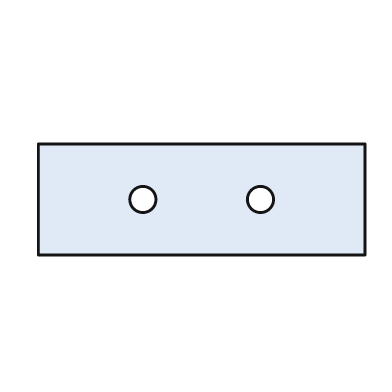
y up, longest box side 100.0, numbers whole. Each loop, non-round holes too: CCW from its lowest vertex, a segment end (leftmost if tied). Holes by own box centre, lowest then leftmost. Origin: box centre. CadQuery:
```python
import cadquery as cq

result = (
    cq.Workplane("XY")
    .moveTo(-50.0, -17.0)
    .lineTo(50.0, -17.0)
    .lineTo(50.0, 17.0)
    .lineTo(-50.0, 17.0)
    .close()
    .moveTo(-18.0, 0.0)
    .circle(4.0)
    .moveTo(18.0, 0.0)
    .circle(4.0)
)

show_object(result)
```